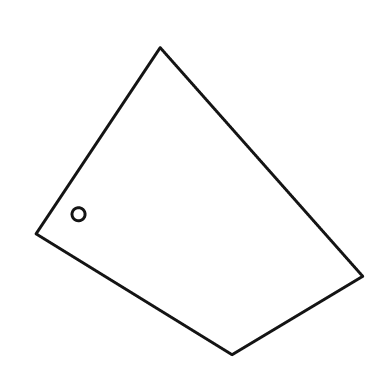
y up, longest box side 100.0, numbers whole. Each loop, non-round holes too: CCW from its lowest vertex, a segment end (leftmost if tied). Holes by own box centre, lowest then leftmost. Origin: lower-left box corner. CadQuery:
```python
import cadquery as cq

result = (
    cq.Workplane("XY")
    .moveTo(60.0, 0.0)
    .lineTo(100.0, 24.0)
    .lineTo(38.0, 94.0)
    .lineTo(0.0, 37.0)
    .close()
    .moveTo(13.0, 43.0)
    .circle(2.0)
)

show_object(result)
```